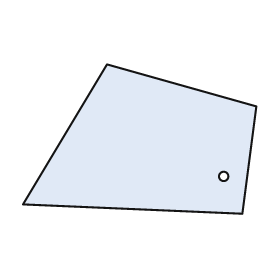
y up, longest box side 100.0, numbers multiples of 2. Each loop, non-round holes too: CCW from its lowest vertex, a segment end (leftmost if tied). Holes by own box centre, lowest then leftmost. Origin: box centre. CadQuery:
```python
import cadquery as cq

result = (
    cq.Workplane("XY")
    .moveTo(44.0, -32.0)
    .lineTo(50.0, 14.0)
    .lineTo(-14.0, 32.0)
    .lineTo(-50.0, -28.0)
    .close()
    .moveTo(36.0, -16.0)
    .circle(2.0)
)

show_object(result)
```